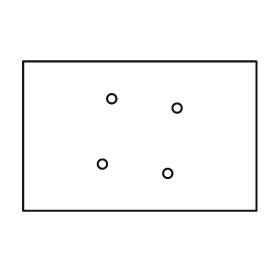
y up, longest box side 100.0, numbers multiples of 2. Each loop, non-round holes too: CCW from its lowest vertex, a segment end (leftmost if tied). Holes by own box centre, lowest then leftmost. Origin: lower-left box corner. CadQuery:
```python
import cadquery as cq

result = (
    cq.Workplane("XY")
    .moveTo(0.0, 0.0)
    .lineTo(100.0, 0.0)
    .lineTo(100.0, 64.0)
    .lineTo(0.0, 64.0)
    .close()
    .moveTo(62.0, 16.0)
    .circle(2.0)
    .moveTo(34.0, 20.0)
    .circle(2.0)
    .moveTo(66.0, 44.0)
    .circle(2.0)
    .moveTo(38.0, 48.0)
    .circle(2.0)
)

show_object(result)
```